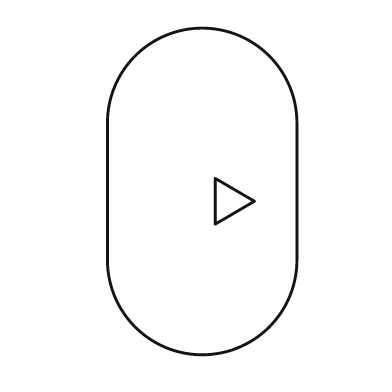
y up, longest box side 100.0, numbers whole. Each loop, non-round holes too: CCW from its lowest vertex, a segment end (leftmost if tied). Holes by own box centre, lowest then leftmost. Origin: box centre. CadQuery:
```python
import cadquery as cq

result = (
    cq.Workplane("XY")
    .moveTo(-29.0, -21.0)
    .threePointArc((0.0, -50.0), (29.0, -21.0))
    .lineTo(29.0, 21.0)
    .threePointArc((0.0, 50.0), (-29.0, 21.0))
    .close()
    .moveTo(4.0, -10.0)
    .lineTo(16.0, -3.0)
    .lineTo(4.0, 4.0)
    .close()
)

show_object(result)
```